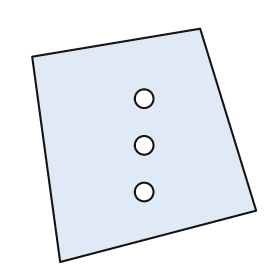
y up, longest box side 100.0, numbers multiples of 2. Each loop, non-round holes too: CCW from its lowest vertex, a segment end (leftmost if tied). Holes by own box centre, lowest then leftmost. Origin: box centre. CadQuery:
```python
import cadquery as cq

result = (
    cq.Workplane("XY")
    .moveTo(-36.0, -50.0)
    .lineTo(48.0, -28.0)
    .lineTo(24.0, 50.0)
    .lineTo(-48.0, 38.0)
    .close()
    .moveTo(0.0, -20.0)
    .circle(4.0)
    .moveTo(0.0, 0.0)
    .circle(4.0)
    .moveTo(0.0, 20.0)
    .circle(4.0)
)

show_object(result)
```